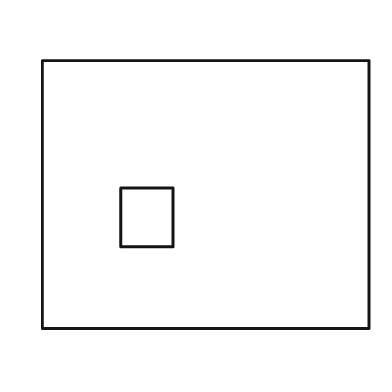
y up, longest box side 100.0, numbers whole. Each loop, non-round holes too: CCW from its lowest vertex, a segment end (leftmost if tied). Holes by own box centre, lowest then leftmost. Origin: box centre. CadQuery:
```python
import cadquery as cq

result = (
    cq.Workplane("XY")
    .moveTo(-50.0, -41.0)
    .lineTo(50.0, -41.0)
    .lineTo(50.0, 41.0)
    .lineTo(-50.0, 41.0)
    .close()
    .moveTo(-26.0, -16.0)
    .lineTo(-10.0, -16.0)
    .lineTo(-10.0, 2.0)
    .lineTo(-26.0, 2.0)
    .close()
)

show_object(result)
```